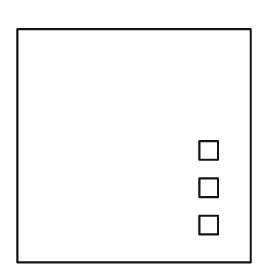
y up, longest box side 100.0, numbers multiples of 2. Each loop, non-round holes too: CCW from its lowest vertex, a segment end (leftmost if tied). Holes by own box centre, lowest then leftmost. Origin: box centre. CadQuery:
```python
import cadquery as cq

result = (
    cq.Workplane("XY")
    .moveTo(-50.0, -50.0)
    .lineTo(50.0, -50.0)
    .lineTo(50.0, 50.0)
    .lineTo(-50.0, 50.0)
    .close()
    .moveTo(28.0, -38.0)
    .lineTo(36.0, -38.0)
    .lineTo(36.0, -30.0)
    .lineTo(28.0, -30.0)
    .close()
    .moveTo(28.0, -22.0)
    .lineTo(36.0, -22.0)
    .lineTo(36.0, -14.0)
    .lineTo(28.0, -14.0)
    .close()
    .moveTo(28.0, -6.0)
    .lineTo(36.0, -6.0)
    .lineTo(36.0, 2.0)
    .lineTo(28.0, 2.0)
    .close()
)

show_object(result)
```